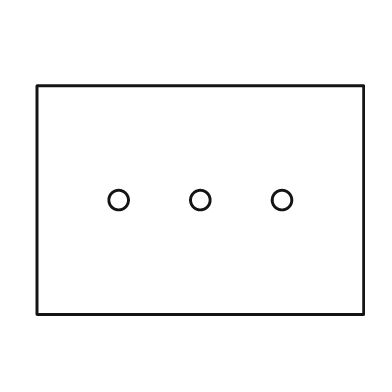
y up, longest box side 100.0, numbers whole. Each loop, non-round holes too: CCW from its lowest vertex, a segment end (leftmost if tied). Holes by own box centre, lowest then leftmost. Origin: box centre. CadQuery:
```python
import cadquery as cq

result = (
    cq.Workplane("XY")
    .moveTo(-50.0, -35.0)
    .lineTo(50.0, -35.0)
    .lineTo(50.0, 35.0)
    .lineTo(-50.0, 35.0)
    .close()
    .moveTo(-25.0, 0.0)
    .circle(3.0)
    .moveTo(0.0, 0.0)
    .circle(3.0)
    .moveTo(25.0, 0.0)
    .circle(3.0)
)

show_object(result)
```